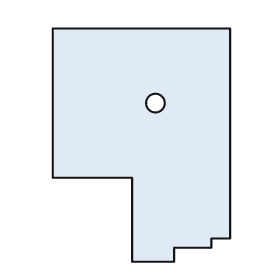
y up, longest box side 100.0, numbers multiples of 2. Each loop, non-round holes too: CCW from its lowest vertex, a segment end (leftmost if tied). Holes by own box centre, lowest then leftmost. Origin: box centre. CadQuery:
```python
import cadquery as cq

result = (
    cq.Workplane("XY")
    .moveTo(-4.0, -50.0)
    .lineTo(14.0, -50.0)
    .lineTo(14.0, -44.0)
    .lineTo(30.0, -44.0)
    .lineTo(30.0, -40.0)
    .lineTo(38.0, -40.0)
    .lineTo(38.0, 50.0)
    .lineTo(-38.0, 50.0)
    .lineTo(-38.0, -14.0)
    .lineTo(-4.0, -14.0)
    .close()
    .moveTo(6.0, 18.0)
    .circle(4.0)
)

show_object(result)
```